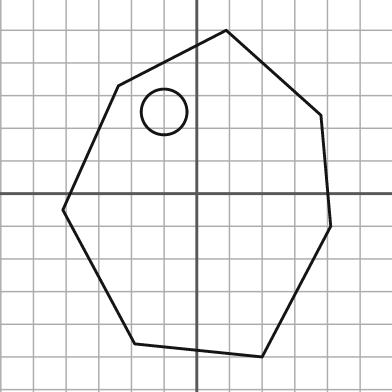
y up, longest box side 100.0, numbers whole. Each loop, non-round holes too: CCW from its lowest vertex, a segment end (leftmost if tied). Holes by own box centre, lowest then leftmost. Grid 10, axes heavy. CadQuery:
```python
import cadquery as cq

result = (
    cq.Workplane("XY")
    .moveTo(20.0, -50.0)
    .lineTo(41.0, -10.0)
    .lineTo(38.0, 24.0)
    .lineTo(9.0, 50.0)
    .lineTo(-24.0, 33.0)
    .lineTo(-41.0, -5.0)
    .lineTo(-19.0, -46.0)
    .close()
    .moveTo(-10.0, 25.0)
    .circle(7.0)
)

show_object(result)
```